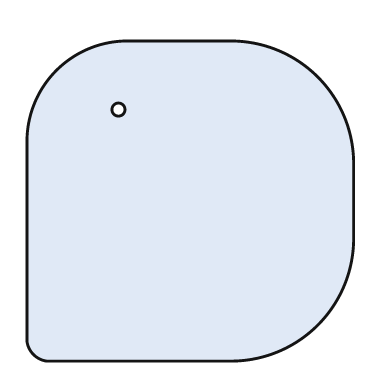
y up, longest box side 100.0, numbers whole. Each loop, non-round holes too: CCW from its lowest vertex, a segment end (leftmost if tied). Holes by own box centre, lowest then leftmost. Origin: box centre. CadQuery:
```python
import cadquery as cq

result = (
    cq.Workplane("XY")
    .moveTo(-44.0, -49.0)
    .lineTo(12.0, -49.0)
    .threePointArc((39.0, -38.0), (50.0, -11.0))
    .lineTo(50.0, 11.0)
    .threePointArc((39.0, 38.0), (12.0, 49.0))
    .lineTo(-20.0, 49.0)
    .threePointArc((-41.0, 40.0), (-50.0, 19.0))
    .lineTo(-50.0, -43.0)
    .threePointArc((-48.0, -47.0), (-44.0, -49.0))
    .close()
    .moveTo(-22.0, 28.0)
    .circle(2.0)
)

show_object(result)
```